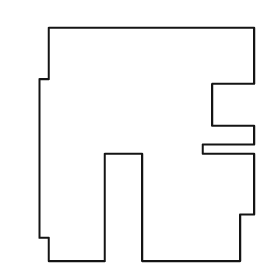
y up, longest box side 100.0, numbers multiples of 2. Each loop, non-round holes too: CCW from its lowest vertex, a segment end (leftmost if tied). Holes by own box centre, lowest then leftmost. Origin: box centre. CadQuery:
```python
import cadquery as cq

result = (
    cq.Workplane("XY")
    .moveTo(-42.0, -50.0)
    .lineTo(-18.0, -50.0)
    .lineTo(-18.0, -4.0)
    .lineTo(-2.0, -4.0)
    .lineTo(-2.0, -50.0)
    .lineTo(40.0, -50.0)
    .lineTo(40.0, -30.0)
    .lineTo(46.0, -30.0)
    .lineTo(46.0, -4.0)
    .lineTo(24.0, -4.0)
    .lineTo(24.0, 0.0)
    .lineTo(46.0, 0.0)
    .lineTo(46.0, 8.0)
    .lineTo(28.0, 8.0)
    .lineTo(28.0, 26.0)
    .lineTo(46.0, 26.0)
    .lineTo(46.0, 50.0)
    .lineTo(-42.0, 50.0)
    .lineTo(-42.0, 28.0)
    .lineTo(-46.0, 28.0)
    .lineTo(-46.0, -40.0)
    .lineTo(-42.0, -40.0)
    .close()
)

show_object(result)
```